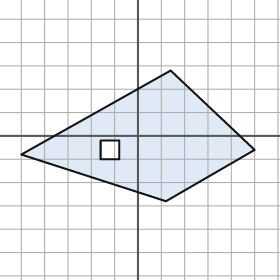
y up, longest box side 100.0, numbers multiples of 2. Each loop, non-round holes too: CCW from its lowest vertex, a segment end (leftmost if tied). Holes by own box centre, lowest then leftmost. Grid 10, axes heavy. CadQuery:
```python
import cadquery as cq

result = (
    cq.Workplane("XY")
    .moveTo(12.0, -28.0)
    .lineTo(50.0, -6.0)
    .lineTo(14.0, 28.0)
    .lineTo(-50.0, -8.0)
    .close()
    .moveTo(-16.0, -10.0)
    .lineTo(-8.0, -10.0)
    .lineTo(-8.0, -2.0)
    .lineTo(-16.0, -2.0)
    .close()
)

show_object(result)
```